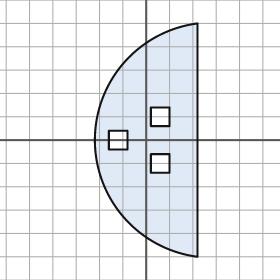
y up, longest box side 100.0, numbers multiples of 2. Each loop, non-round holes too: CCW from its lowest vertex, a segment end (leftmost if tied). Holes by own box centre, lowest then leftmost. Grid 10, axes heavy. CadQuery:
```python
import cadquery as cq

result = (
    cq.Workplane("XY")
    .moveTo(22.0, -50.0)
    .lineTo(22.0, 50.0)
    .threePointArc((-22.0, 0.0), (22.0, -50.0))
    .close()
    .moveTo(2.0, -14.0)
    .lineTo(10.0, -14.0)
    .lineTo(10.0, -6.0)
    .lineTo(2.0, -6.0)
    .close()
    .moveTo(-16.0, -4.0)
    .lineTo(-8.0, -4.0)
    .lineTo(-8.0, 4.0)
    .lineTo(-16.0, 4.0)
    .close()
    .moveTo(2.0, 6.0)
    .lineTo(10.0, 6.0)
    .lineTo(10.0, 14.0)
    .lineTo(2.0, 14.0)
    .close()
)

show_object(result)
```